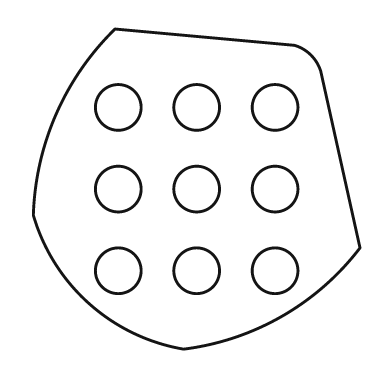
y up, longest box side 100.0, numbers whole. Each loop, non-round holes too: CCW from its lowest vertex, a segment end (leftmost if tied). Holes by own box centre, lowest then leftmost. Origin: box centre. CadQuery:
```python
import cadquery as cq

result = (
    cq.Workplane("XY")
    .moveTo(-4.0, -49.0)
    .threePointArc((26.0, -39.0), (50.0, -18.0))
    .lineTo(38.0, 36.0)
    .threePointArc((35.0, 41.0), (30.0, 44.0))
    .lineTo(-25.0, 49.0)
    .threePointArc((-43.0, 23.0), (-50.0, -8.0))
    .threePointArc((-33.0, -35.0), (-4.0, -49.0))
    .close()
    .moveTo(-24.0, -25.0)
    .circle(7.0)
    .moveTo(0.0, -25.0)
    .circle(7.0)
    .moveTo(24.0, -25.0)
    .circle(7.0)
    .moveTo(-24.0, 0.0)
    .circle(7.0)
    .moveTo(0.0, 0.0)
    .circle(7.0)
    .moveTo(24.0, 0.0)
    .circle(7.0)
    .moveTo(-24.0, 25.0)
    .circle(7.0)
    .moveTo(0.0, 25.0)
    .circle(7.0)
    .moveTo(24.0, 25.0)
    .circle(7.0)
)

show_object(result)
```